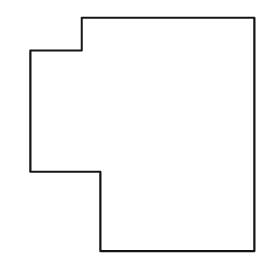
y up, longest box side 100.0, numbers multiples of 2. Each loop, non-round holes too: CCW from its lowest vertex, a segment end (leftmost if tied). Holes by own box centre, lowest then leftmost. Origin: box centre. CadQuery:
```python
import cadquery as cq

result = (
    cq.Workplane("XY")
    .moveTo(-18.0, -50.0)
    .lineTo(48.0, -50.0)
    .lineTo(48.0, 50.0)
    .lineTo(-26.0, 50.0)
    .lineTo(-26.0, 36.0)
    .lineTo(-48.0, 36.0)
    .lineTo(-48.0, -16.0)
    .lineTo(-18.0, -16.0)
    .close()
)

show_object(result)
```